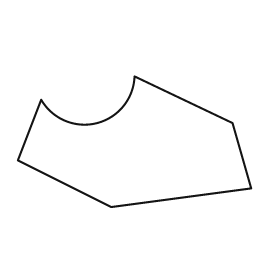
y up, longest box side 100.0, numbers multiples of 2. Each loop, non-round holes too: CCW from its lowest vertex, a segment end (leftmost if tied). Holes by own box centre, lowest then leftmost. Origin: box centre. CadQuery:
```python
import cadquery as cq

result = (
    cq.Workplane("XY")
    .moveTo(-10.0, -28.0)
    .lineTo(50.0, -20.0)
    .lineTo(42.0, 8.0)
    .lineTo(0.0, 28.0)
    .threePointArc((-16.0, 8.0), (-40.0, 18.0))
    .lineTo(-50.0, -8.0)
    .close()
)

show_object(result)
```